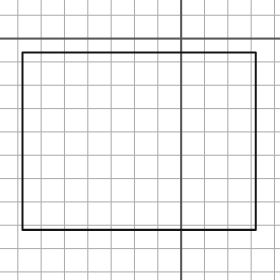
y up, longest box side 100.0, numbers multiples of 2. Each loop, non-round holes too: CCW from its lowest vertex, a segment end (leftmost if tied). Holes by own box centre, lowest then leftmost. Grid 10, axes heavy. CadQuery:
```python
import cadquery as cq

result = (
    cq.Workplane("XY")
    .moveTo(-68.0, -82.0)
    .lineTo(32.0, -82.0)
    .lineTo(32.0, -6.0)
    .lineTo(-68.0, -6.0)
    .close()
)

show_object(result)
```